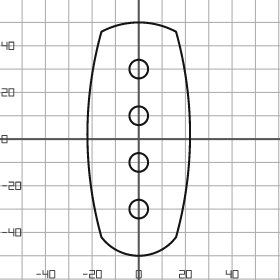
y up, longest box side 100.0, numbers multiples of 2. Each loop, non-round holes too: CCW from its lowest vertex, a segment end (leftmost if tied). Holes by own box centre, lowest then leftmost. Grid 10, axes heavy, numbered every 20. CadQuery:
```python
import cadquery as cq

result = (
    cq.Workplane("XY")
    .moveTo(-16.0, -42.0)
    .threePointArc((0.0, -50.0), (16.0, -42.0))
    .threePointArc((22.0, 2.0), (16.0, 46.0))
    .threePointArc((0.0, 50.0), (-16.0, 46.0))
    .threePointArc((-22.0, 2.0), (-16.0, -42.0))
    .close()
    .moveTo(0.0, -30.0)
    .circle(4.0)
    .moveTo(0.0, -10.0)
    .circle(4.0)
    .moveTo(0.0, 10.0)
    .circle(4.0)
    .moveTo(0.0, 30.0)
    .circle(4.0)
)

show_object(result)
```